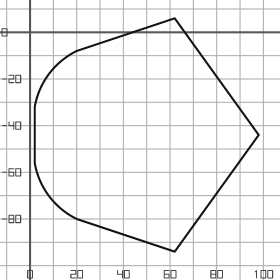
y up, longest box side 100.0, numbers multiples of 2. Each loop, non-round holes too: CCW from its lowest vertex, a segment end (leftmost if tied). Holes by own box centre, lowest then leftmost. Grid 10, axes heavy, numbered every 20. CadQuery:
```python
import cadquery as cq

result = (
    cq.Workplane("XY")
    .moveTo(62.0, -94.0)
    .lineTo(98.0, -44.0)
    .lineTo(62.0, 6.0)
    .lineTo(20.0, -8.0)
    .threePointArc((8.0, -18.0), (2.0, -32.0))
    .lineTo(2.0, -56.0)
    .threePointArc((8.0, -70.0), (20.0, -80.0))
    .close()
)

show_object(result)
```